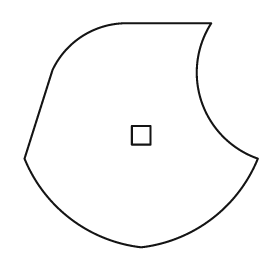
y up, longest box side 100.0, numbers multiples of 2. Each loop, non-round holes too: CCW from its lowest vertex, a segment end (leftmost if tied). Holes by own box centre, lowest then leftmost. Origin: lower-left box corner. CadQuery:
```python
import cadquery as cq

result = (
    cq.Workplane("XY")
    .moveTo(50.0, 0.0)
    .threePointArc((80.0, 12.0), (100.0, 38.0))
    .threePointArc((76.0, 62.0), (80.0, 96.0))
    .lineTo(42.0, 96.0)
    .threePointArc((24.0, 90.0), (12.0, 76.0))
    .lineTo(0.0, 38.0)
    .threePointArc((20.0, 12.0), (50.0, 0.0))
    .close()
    .moveTo(46.0, 44.0)
    .lineTo(54.0, 44.0)
    .lineTo(54.0, 52.0)
    .lineTo(46.0, 52.0)
    .close()
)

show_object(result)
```